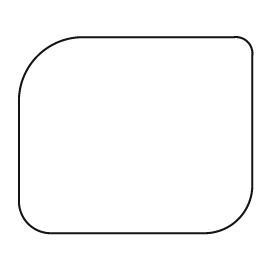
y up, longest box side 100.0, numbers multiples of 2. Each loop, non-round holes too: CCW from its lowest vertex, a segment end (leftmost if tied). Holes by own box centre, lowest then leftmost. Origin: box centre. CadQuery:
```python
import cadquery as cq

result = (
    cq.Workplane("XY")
    .moveTo(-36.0, -42.0)
    .lineTo(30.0, -42.0)
    .threePointArc((44.0, -36.0), (50.0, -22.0))
    .lineTo(50.0, 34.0)
    .threePointArc((48.0, 40.0), (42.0, 42.0))
    .lineTo(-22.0, 42.0)
    .threePointArc((-42.0, 34.0), (-50.0, 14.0))
    .lineTo(-50.0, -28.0)
    .threePointArc((-46.0, -38.0), (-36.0, -42.0))
    .close()
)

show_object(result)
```